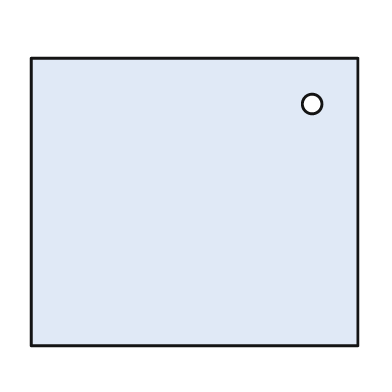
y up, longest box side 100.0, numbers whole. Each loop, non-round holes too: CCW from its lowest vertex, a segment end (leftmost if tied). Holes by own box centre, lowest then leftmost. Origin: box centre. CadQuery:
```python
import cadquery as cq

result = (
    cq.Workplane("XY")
    .moveTo(-50.0, -44.0)
    .lineTo(50.0, -44.0)
    .lineTo(50.0, 44.0)
    .lineTo(-50.0, 44.0)
    .close()
    .moveTo(36.0, 30.0)
    .circle(3.0)
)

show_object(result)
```